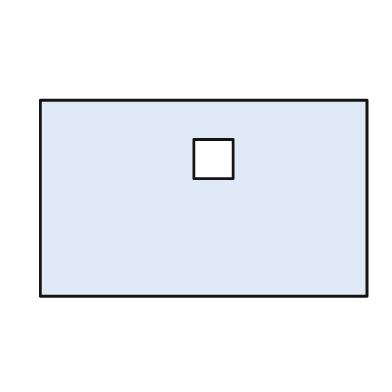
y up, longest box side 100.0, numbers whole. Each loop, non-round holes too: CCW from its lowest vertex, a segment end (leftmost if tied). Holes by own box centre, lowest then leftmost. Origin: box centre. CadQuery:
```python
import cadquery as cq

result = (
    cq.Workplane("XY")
    .moveTo(-50.0, -30.0)
    .lineTo(50.0, -30.0)
    .lineTo(50.0, 30.0)
    .lineTo(-50.0, 30.0)
    .close()
    .moveTo(-3.0, 6.0)
    .lineTo(9.0, 6.0)
    .lineTo(9.0, 18.0)
    .lineTo(-3.0, 18.0)
    .close()
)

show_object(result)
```